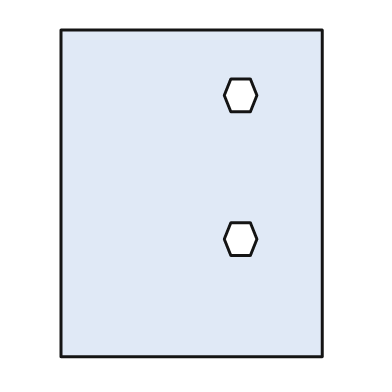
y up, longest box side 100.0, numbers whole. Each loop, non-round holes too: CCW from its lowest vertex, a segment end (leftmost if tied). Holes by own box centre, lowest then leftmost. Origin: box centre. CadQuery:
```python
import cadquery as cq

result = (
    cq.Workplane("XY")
    .moveTo(-40.0, -50.0)
    .lineTo(40.0, -50.0)
    .lineTo(40.0, 50.0)
    .lineTo(-40.0, 50.0)
    .close()
    .moveTo(12.0, -19.0)
    .lineTo(18.0, -19.0)
    .lineTo(20.0, -14.0)
    .lineTo(18.0, -9.0)
    .lineTo(12.0, -9.0)
    .lineTo(10.0, -14.0)
    .close()
    .moveTo(12.0, 25.0)
    .lineTo(18.0, 25.0)
    .lineTo(20.0, 30.0)
    .lineTo(18.0, 35.0)
    .lineTo(12.0, 35.0)
    .lineTo(10.0, 30.0)
    .close()
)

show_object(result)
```